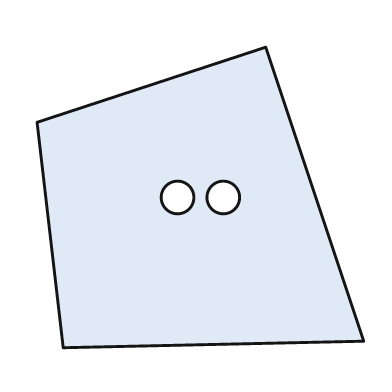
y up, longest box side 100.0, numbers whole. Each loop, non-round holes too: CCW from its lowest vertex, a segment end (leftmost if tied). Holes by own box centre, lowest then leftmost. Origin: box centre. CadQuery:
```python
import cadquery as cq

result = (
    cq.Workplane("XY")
    .moveTo(-42.0, -46.0)
    .lineTo(50.0, -44.0)
    .lineTo(20.0, 46.0)
    .lineTo(-50.0, 23.0)
    .close()
    .moveTo(-7.0, 0.0)
    .circle(5.0)
    .moveTo(7.0, 0.0)
    .circle(5.0)
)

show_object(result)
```